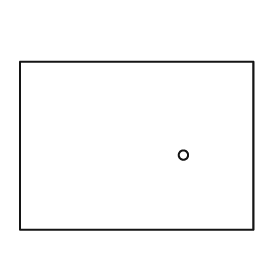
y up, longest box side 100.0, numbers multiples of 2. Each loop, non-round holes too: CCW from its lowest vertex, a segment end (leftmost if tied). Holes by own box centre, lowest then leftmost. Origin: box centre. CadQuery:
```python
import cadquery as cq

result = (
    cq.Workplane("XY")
    .moveTo(-50.0, -36.0)
    .lineTo(50.0, -36.0)
    .lineTo(50.0, 36.0)
    .lineTo(-50.0, 36.0)
    .close()
    .moveTo(20.0, -4.0)
    .circle(2.0)
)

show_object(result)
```